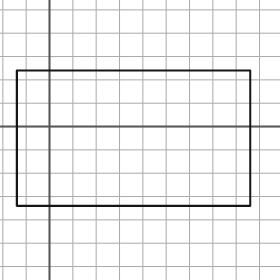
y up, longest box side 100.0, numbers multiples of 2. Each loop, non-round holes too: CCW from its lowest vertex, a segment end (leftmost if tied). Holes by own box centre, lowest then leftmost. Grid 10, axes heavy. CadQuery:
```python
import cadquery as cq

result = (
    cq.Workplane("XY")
    .moveTo(-14.0, -34.0)
    .lineTo(86.0, -34.0)
    .lineTo(86.0, 24.0)
    .lineTo(-14.0, 24.0)
    .close()
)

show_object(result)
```